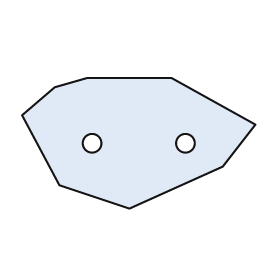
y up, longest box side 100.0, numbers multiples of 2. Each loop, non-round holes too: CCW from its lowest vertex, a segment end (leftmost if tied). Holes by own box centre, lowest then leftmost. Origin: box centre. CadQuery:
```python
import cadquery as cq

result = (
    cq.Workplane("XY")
    .moveTo(-4.0, -28.0)
    .lineTo(36.0, -10.0)
    .lineTo(50.0, 8.0)
    .lineTo(14.0, 28.0)
    .lineTo(-22.0, 28.0)
    .lineTo(-36.0, 24.0)
    .lineTo(-50.0, 12.0)
    .lineTo(-34.0, -18.0)
    .close()
    .moveTo(-20.0, 0.0)
    .circle(4.0)
    .moveTo(20.0, 0.0)
    .circle(4.0)
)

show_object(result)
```